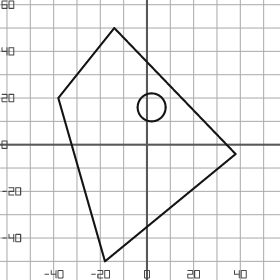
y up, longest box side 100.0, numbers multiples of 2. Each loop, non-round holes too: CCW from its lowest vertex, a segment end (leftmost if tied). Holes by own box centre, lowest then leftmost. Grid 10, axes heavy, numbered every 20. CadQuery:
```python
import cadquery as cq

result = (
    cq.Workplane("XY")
    .moveTo(-18.0, -50.0)
    .lineTo(38.0, -4.0)
    .lineTo(-14.0, 50.0)
    .lineTo(-38.0, 20.0)
    .close()
    .moveTo(2.0, 16.0)
    .circle(6.0)
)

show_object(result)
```